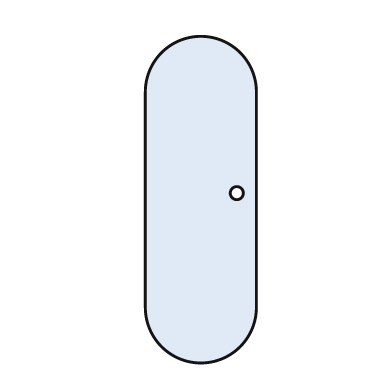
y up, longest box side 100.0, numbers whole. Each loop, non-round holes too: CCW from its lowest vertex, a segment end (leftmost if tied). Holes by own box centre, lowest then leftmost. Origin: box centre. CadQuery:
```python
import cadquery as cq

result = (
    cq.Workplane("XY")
    .moveTo(-17.0, -33.0)
    .threePointArc((0.0, -50.0), (17.0, -33.0))
    .lineTo(17.0, 33.0)
    .threePointArc((0.0, 50.0), (-17.0, 33.0))
    .close()
    .moveTo(11.0, 2.0)
    .circle(2.0)
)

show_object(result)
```